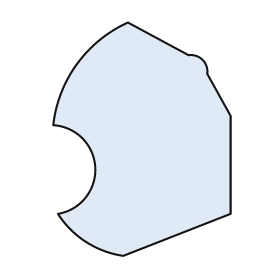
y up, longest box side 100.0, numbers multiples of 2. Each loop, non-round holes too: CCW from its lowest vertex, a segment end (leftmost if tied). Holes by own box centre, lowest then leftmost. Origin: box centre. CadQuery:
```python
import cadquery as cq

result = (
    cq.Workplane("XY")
    .moveTo(-8.0, -50.0)
    .lineTo(38.0, -32.0)
    .lineTo(38.0, 10.0)
    .lineTo(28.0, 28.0)
    .threePointArc((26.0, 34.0), (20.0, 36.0))
    .lineTo(-6.0, 50.0)
    .threePointArc((-28.0, 32.0), (-38.0, 6.0))
    .threePointArc((-20.0, -12.0), (-36.0, -32.0))
    .threePointArc((-24.0, -44.0), (-8.0, -50.0))
    .close()
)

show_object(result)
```